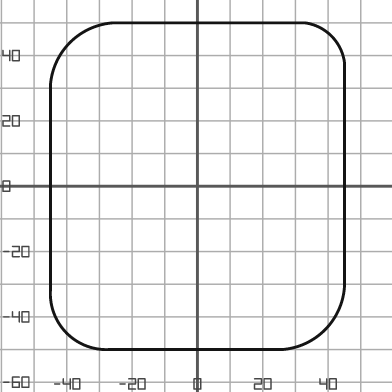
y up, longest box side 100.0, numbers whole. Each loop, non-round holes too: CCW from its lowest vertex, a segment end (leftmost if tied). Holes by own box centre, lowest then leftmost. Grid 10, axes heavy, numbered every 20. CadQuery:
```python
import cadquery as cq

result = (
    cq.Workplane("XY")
    .moveTo(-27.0, -50.0)
    .lineTo(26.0, -50.0)
    .threePointArc((39.0, -44.0), (45.0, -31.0))
    .lineTo(45.0, 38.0)
    .threePointArc((41.0, 46.0), (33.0, 50.0))
    .lineTo(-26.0, 50.0)
    .threePointArc((-39.0, 44.0), (-45.0, 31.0))
    .lineTo(-45.0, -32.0)
    .threePointArc((-40.0, -45.0), (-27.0, -50.0))
    .close()
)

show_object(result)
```